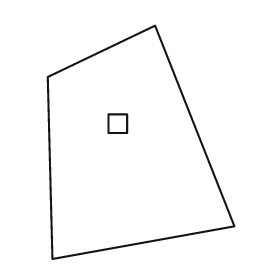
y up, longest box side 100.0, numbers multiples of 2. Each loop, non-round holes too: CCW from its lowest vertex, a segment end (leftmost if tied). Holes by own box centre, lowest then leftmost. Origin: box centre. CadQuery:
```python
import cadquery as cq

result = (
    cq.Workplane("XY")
    .moveTo(-38.0, -50.0)
    .lineTo(40.0, -36.0)
    .lineTo(6.0, 50.0)
    .lineTo(-40.0, 28.0)
    .close()
    .moveTo(-14.0, 4.0)
    .lineTo(-6.0, 4.0)
    .lineTo(-6.0, 12.0)
    .lineTo(-14.0, 12.0)
    .close()
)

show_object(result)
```